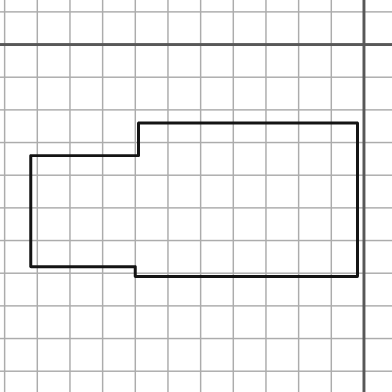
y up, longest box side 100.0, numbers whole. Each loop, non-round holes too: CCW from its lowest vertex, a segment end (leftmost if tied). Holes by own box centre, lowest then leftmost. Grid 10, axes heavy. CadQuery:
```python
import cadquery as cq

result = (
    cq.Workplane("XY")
    .moveTo(-70.0, -71.0)
    .lineTo(-2.0, -71.0)
    .lineTo(-2.0, -24.0)
    .lineTo(-69.0, -24.0)
    .lineTo(-69.0, -34.0)
    .lineTo(-102.0, -34.0)
    .lineTo(-102.0, -68.0)
    .lineTo(-70.0, -68.0)
    .close()
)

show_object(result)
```